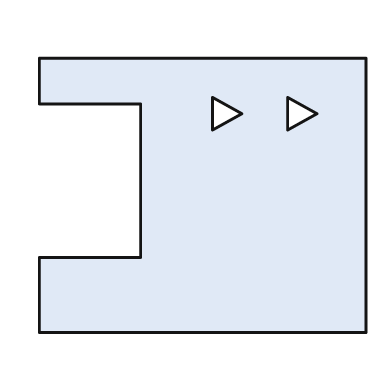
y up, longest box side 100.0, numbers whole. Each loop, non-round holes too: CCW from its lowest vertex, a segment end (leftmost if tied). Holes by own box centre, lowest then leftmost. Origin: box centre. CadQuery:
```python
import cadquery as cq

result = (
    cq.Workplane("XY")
    .moveTo(-50.0, -42.0)
    .lineTo(50.0, -42.0)
    .lineTo(50.0, 42.0)
    .lineTo(-50.0, 42.0)
    .lineTo(-50.0, 28.0)
    .lineTo(-19.0, 28.0)
    .lineTo(-19.0, -19.0)
    .lineTo(-50.0, -19.0)
    .close()
    .moveTo(3.0, 20.0)
    .lineTo(12.0, 25.0)
    .lineTo(3.0, 30.0)
    .close()
    .moveTo(26.0, 20.0)
    .lineTo(35.0, 25.0)
    .lineTo(26.0, 30.0)
    .close()
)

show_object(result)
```